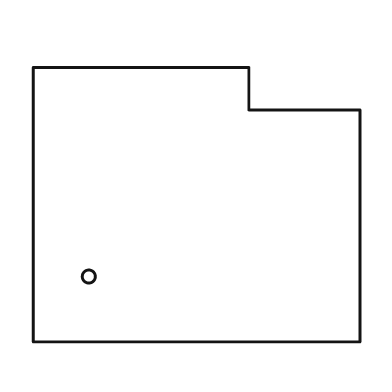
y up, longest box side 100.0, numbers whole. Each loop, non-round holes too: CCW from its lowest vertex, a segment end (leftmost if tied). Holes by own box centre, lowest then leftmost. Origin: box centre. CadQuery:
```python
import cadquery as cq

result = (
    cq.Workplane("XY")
    .moveTo(-50.0, -42.0)
    .lineTo(50.0, -42.0)
    .lineTo(50.0, 29.0)
    .lineTo(16.0, 29.0)
    .lineTo(16.0, 42.0)
    .lineTo(-50.0, 42.0)
    .close()
    .moveTo(-33.0, -22.0)
    .circle(2.0)
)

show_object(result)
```